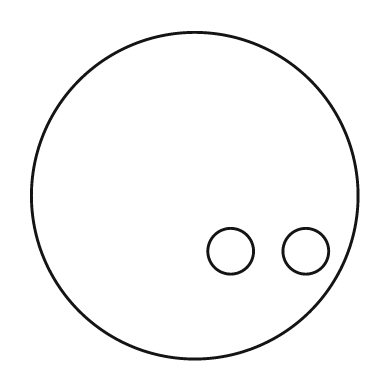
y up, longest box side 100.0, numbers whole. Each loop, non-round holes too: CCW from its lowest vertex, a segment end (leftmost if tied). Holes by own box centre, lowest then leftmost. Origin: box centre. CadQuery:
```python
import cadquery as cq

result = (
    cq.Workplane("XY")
    .moveTo(0.0, 0.0)
    .circle(50.0)
    .moveTo(11.0, -17.0)
    .circle(7.0)
    .moveTo(34.0, -17.0)
    .circle(7.0)
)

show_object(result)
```